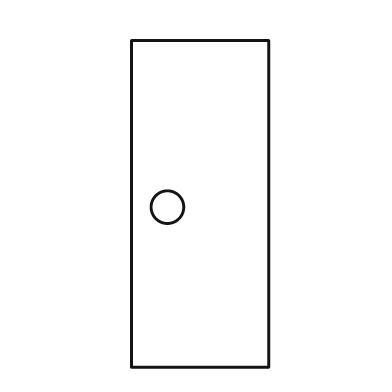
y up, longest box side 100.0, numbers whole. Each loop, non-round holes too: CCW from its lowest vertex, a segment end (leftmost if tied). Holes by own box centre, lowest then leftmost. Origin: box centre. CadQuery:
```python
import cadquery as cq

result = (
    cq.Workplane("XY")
    .moveTo(-21.0, -50.0)
    .lineTo(21.0, -50.0)
    .lineTo(21.0, 50.0)
    .lineTo(-21.0, 50.0)
    .close()
    .moveTo(-10.0, -1.0)
    .circle(5.0)
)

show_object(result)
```